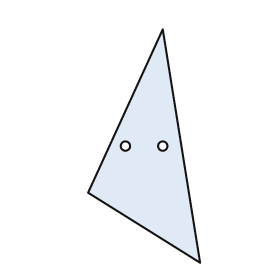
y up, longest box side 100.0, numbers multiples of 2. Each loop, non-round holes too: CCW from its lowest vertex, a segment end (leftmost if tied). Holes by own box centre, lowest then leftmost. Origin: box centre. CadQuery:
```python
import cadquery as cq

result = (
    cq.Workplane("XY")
    .moveTo(24.0, -50.0)
    .lineTo(8.0, 50.0)
    .lineTo(-24.0, -20.0)
    .close()
    .moveTo(-8.0, 0.0)
    .circle(2.0)
    .moveTo(8.0, 0.0)
    .circle(2.0)
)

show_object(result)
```